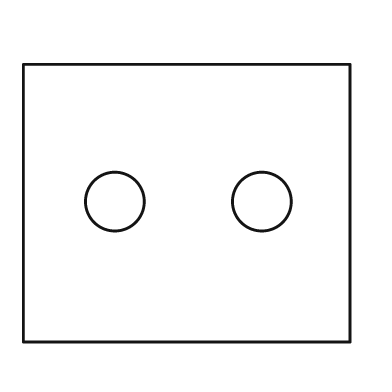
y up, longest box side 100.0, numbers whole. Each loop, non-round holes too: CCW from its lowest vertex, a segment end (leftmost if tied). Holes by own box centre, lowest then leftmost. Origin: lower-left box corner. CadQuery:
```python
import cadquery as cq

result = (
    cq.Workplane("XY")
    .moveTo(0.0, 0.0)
    .lineTo(100.0, 0.0)
    .lineTo(100.0, 85.0)
    .lineTo(0.0, 85.0)
    .close()
    .moveTo(28.0, 43.0)
    .circle(9.0)
    .moveTo(73.0, 43.0)
    .circle(9.0)
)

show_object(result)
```